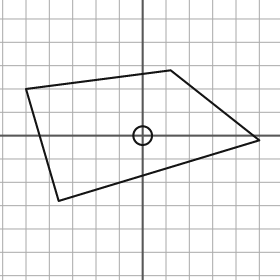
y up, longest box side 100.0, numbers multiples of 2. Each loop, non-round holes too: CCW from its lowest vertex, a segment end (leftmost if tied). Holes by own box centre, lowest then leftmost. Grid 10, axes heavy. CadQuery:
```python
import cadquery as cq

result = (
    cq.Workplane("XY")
    .moveTo(-36.0, -28.0)
    .lineTo(50.0, -2.0)
    .lineTo(12.0, 28.0)
    .lineTo(-50.0, 20.0)
    .close()
    .moveTo(0.0, 0.0)
    .circle(4.0)
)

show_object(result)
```